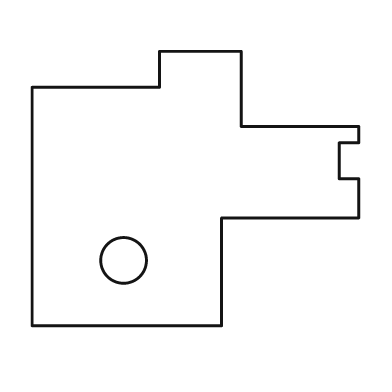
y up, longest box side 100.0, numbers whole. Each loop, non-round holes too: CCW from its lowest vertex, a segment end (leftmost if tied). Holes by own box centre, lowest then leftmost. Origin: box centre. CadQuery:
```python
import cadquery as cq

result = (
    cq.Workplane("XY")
    .moveTo(-50.0, -42.0)
    .lineTo(8.0, -42.0)
    .lineTo(8.0, -9.0)
    .lineTo(50.0, -9.0)
    .lineTo(50.0, 3.0)
    .lineTo(44.0, 3.0)
    .lineTo(44.0, 14.0)
    .lineTo(50.0, 14.0)
    .lineTo(50.0, 19.0)
    .lineTo(14.0, 19.0)
    .lineTo(14.0, 42.0)
    .lineTo(-11.0, 42.0)
    .lineTo(-11.0, 31.0)
    .lineTo(-50.0, 31.0)
    .close()
    .moveTo(-22.0, -22.0)
    .circle(7.0)
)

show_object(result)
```